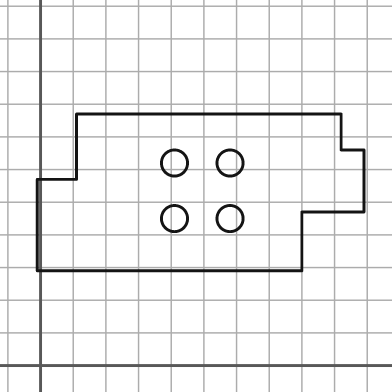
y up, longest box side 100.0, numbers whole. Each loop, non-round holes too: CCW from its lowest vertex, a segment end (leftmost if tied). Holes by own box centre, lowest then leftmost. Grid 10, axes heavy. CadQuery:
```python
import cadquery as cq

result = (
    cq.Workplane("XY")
    .moveTo(-1.0, 29.0)
    .lineTo(80.0, 29.0)
    .lineTo(80.0, 47.0)
    .lineTo(99.0, 47.0)
    .lineTo(99.0, 66.0)
    .lineTo(92.0, 66.0)
    .lineTo(92.0, 77.0)
    .lineTo(11.0, 77.0)
    .lineTo(11.0, 57.0)
    .lineTo(-1.0, 57.0)
    .close()
    .moveTo(41.0, 45.0)
    .circle(4.0)
    .moveTo(58.0, 45.0)
    .circle(4.0)
    .moveTo(41.0, 62.0)
    .circle(4.0)
    .moveTo(58.0, 62.0)
    .circle(4.0)
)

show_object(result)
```